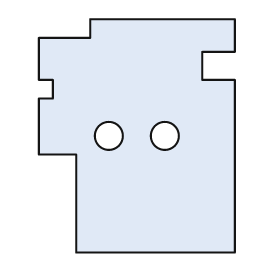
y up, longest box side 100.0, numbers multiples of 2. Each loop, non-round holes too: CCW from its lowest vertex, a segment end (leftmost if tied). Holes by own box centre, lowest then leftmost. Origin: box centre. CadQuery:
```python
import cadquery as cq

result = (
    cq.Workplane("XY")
    .moveTo(-26.0, -50.0)
    .lineTo(42.0, -50.0)
    .lineTo(42.0, 24.0)
    .lineTo(28.0, 24.0)
    .lineTo(28.0, 36.0)
    .lineTo(42.0, 36.0)
    .lineTo(42.0, 50.0)
    .lineTo(-20.0, 50.0)
    .lineTo(-20.0, 42.0)
    .lineTo(-42.0, 42.0)
    .lineTo(-42.0, 24.0)
    .lineTo(-36.0, 24.0)
    .lineTo(-36.0, 16.0)
    .lineTo(-42.0, 16.0)
    .lineTo(-42.0, -8.0)
    .lineTo(-26.0, -8.0)
    .close()
    .moveTo(-12.0, 0.0)
    .circle(6.0)
    .moveTo(12.0, 0.0)
    .circle(6.0)
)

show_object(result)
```